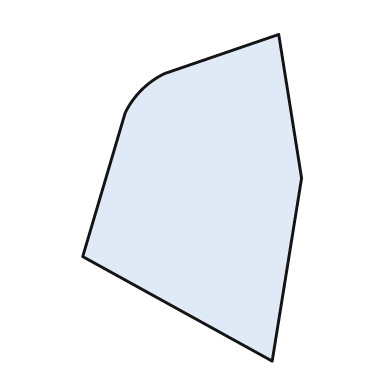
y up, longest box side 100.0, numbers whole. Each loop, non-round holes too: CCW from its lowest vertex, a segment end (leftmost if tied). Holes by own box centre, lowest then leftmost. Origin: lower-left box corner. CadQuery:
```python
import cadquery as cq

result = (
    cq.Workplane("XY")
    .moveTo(58.0, 0.0)
    .lineTo(67.0, 56.0)
    .lineTo(60.0, 100.0)
    .lineTo(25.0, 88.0)
    .threePointArc((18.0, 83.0), (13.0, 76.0))
    .lineTo(0.0, 32.0)
    .close()
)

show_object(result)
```